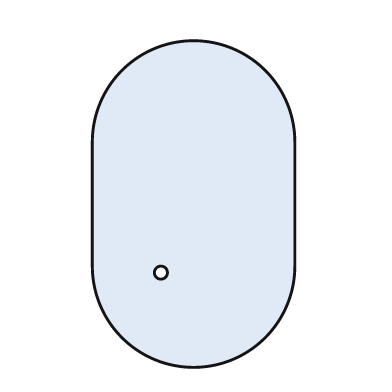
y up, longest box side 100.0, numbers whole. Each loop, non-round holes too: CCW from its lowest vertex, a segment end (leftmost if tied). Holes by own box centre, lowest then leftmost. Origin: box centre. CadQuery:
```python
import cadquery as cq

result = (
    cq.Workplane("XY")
    .moveTo(-31.0, -19.0)
    .threePointArc((0.0, -50.0), (31.0, -19.0))
    .lineTo(31.0, 19.0)
    .threePointArc((0.0, 50.0), (-31.0, 19.0))
    .close()
    .moveTo(-10.0, -21.0)
    .circle(2.0)
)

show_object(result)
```